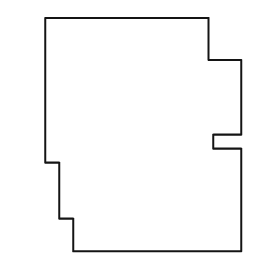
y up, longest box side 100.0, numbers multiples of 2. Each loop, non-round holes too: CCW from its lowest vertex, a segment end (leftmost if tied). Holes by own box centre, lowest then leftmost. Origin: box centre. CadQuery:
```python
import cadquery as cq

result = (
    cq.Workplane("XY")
    .moveTo(-30.0, -50.0)
    .lineTo(42.0, -50.0)
    .lineTo(42.0, -6.0)
    .lineTo(30.0, -6.0)
    .lineTo(30.0, 0.0)
    .lineTo(42.0, 0.0)
    .lineTo(42.0, 32.0)
    .lineTo(28.0, 32.0)
    .lineTo(28.0, 50.0)
    .lineTo(-42.0, 50.0)
    .lineTo(-42.0, -12.0)
    .lineTo(-36.0, -12.0)
    .lineTo(-36.0, -36.0)
    .lineTo(-30.0, -36.0)
    .close()
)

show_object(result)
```